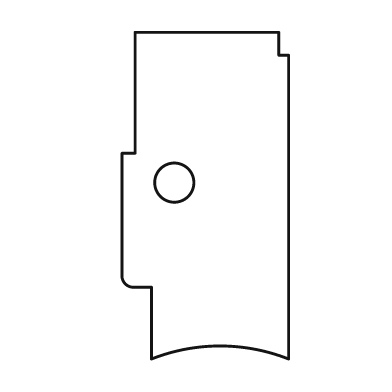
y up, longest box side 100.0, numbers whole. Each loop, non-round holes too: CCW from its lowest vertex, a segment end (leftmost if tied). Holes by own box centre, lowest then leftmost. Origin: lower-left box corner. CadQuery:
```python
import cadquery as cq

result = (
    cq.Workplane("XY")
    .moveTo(9.0, 0.0)
    .threePointArc((30.0, 4.0), (51.0, 0.0))
    .lineTo(51.0, 93.0)
    .lineTo(48.0, 93.0)
    .lineTo(48.0, 100.0)
    .lineTo(4.0, 100.0)
    .lineTo(4.0, 63.0)
    .lineTo(0.0, 63.0)
    .lineTo(0.0, 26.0)
    .threePointArc((1.0, 23.0), (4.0, 22.0))
    .lineTo(9.0, 22.0)
    .close()
    .moveTo(16.0, 54.0)
    .circle(6.0)
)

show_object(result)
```